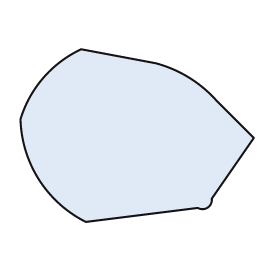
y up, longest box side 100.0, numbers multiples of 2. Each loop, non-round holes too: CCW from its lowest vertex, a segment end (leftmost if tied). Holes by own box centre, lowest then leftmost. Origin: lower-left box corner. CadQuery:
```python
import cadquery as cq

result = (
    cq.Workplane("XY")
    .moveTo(28.0, 0.0)
    .lineTo(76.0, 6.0)
    .threePointArc((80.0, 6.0), (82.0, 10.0))
    .lineTo(100.0, 36.0)
    .lineTo(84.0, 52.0)
    .threePointArc((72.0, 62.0), (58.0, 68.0))
    .lineTo(26.0, 74.0)
    .threePointArc((10.0, 62.0), (0.0, 44.0))
    .threePointArc((8.0, 18.0), (28.0, 0.0))
    .close()
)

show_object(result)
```